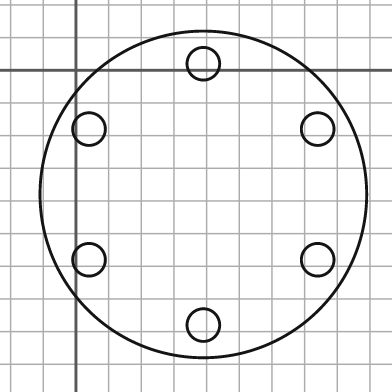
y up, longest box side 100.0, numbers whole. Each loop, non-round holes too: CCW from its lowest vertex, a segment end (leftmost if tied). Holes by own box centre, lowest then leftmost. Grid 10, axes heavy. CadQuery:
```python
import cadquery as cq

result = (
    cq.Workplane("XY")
    .moveTo(39.0, -38.0)
    .circle(50.0)
    .moveTo(39.0, -78.0)
    .circle(5.0)
    .moveTo(4.0, -58.0)
    .circle(5.0)
    .moveTo(74.0, -58.0)
    .circle(5.0)
    .moveTo(4.0, -18.0)
    .circle(5.0)
    .moveTo(74.0, -18.0)
    .circle(5.0)
    .moveTo(39.0, 2.0)
    .circle(5.0)
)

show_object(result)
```